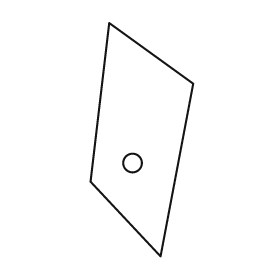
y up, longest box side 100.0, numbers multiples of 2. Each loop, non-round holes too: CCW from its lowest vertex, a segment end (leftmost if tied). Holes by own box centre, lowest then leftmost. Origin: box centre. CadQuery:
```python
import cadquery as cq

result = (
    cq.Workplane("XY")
    .moveTo(8.0, -50.0)
    .lineTo(22.0, 24.0)
    .lineTo(-14.0, 50.0)
    .lineTo(-22.0, -18.0)
    .close()
    .moveTo(-4.0, -10.0)
    .circle(4.0)
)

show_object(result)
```